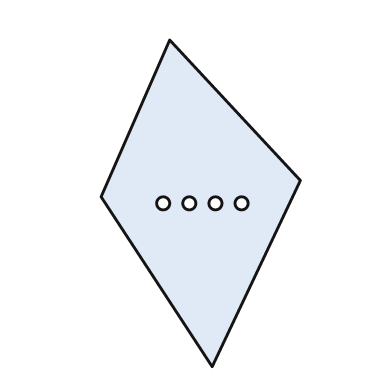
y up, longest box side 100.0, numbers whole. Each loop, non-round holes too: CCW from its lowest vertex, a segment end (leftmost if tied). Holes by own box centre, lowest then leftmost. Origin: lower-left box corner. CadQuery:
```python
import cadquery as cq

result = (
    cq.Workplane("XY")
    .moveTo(34.0, 0.0)
    .lineTo(61.0, 57.0)
    .lineTo(21.0, 100.0)
    .lineTo(0.0, 52.0)
    .close()
    .moveTo(19.0, 50.0)
    .circle(2.0)
    .moveTo(27.0, 50.0)
    .circle(2.0)
    .moveTo(35.0, 50.0)
    .circle(2.0)
    .moveTo(43.0, 50.0)
    .circle(2.0)
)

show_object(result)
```